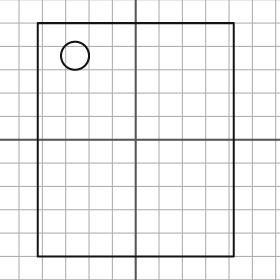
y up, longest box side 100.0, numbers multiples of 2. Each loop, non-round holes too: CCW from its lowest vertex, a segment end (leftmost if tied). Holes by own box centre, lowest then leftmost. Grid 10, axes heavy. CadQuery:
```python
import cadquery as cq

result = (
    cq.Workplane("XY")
    .moveTo(-42.0, -50.0)
    .lineTo(42.0, -50.0)
    .lineTo(42.0, 50.0)
    .lineTo(-42.0, 50.0)
    .close()
    .moveTo(-26.0, 36.0)
    .circle(6.0)
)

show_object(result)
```